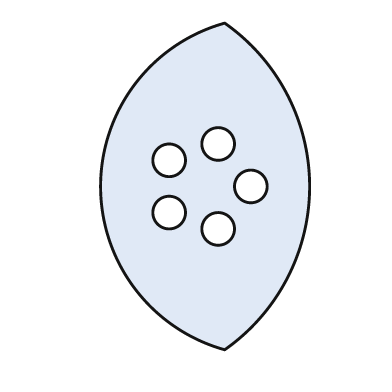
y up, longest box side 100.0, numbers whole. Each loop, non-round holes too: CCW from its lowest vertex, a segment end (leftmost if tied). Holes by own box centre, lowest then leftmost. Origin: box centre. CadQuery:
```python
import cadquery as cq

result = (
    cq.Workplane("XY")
    .moveTo(6.0, -50.0)
    .threePointArc((32.0, 0.0), (6.0, 50.0))
    .threePointArc((-32.0, 0.0), (6.0, -50.0))
    .close()
    .moveTo(4.0, -13.0)
    .circle(5.0)
    .moveTo(-11.0, -8.0)
    .circle(5.0)
    .moveTo(14.0, 0.0)
    .circle(5.0)
    .moveTo(-11.0, 8.0)
    .circle(5.0)
    .moveTo(4.0, 13.0)
    .circle(5.0)
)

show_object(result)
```